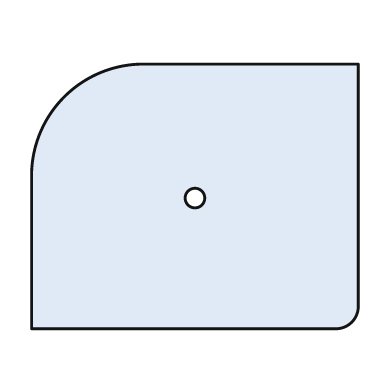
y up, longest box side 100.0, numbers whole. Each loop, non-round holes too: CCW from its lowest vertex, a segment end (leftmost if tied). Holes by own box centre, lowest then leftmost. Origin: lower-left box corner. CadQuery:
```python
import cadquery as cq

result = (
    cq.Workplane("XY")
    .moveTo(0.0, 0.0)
    .lineTo(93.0, 0.0)
    .threePointArc((98.0, 2.0), (100.0, 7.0))
    .lineTo(100.0, 81.0)
    .lineTo(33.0, 81.0)
    .threePointArc((10.0, 71.0), (0.0, 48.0))
    .close()
    .moveTo(50.0, 40.0)
    .circle(3.0)
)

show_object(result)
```